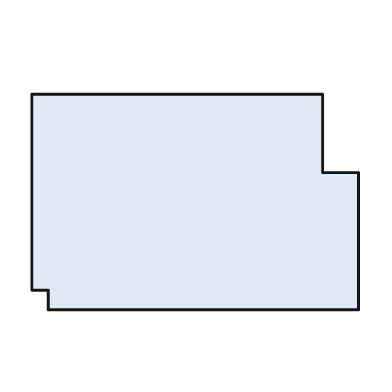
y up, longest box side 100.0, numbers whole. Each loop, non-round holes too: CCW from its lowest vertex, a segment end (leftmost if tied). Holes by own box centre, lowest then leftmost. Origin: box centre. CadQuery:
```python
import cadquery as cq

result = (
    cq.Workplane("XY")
    .moveTo(-45.0, -33.0)
    .lineTo(50.0, -33.0)
    .lineTo(50.0, 9.0)
    .lineTo(39.0, 9.0)
    .lineTo(39.0, 33.0)
    .lineTo(-50.0, 33.0)
    .lineTo(-50.0, -27.0)
    .lineTo(-45.0, -27.0)
    .close()
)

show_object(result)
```